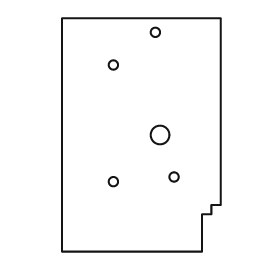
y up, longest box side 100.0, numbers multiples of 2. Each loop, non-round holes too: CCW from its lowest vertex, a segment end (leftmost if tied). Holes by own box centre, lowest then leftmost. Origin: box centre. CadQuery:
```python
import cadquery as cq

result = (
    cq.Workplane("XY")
    .moveTo(-34.0, -50.0)
    .lineTo(26.0, -50.0)
    .lineTo(26.0, -34.0)
    .lineTo(30.0, -34.0)
    .lineTo(30.0, -30.0)
    .lineTo(34.0, -30.0)
    .lineTo(34.0, 50.0)
    .lineTo(-34.0, 50.0)
    .close()
    .moveTo(-12.0, -20.0)
    .circle(2.0)
    .moveTo(14.0, -18.0)
    .circle(2.0)
    .moveTo(8.0, 0.0)
    .circle(4.0)
    .moveTo(-12.0, 30.0)
    .circle(2.0)
    .moveTo(6.0, 44.0)
    .circle(2.0)
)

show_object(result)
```